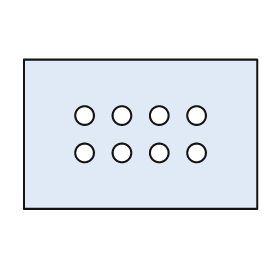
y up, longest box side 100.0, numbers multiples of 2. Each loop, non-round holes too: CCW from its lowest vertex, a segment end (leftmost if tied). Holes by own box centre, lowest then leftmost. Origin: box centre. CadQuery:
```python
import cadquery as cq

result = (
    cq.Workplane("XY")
    .moveTo(-50.0, -32.0)
    .lineTo(50.0, -32.0)
    .lineTo(50.0, 32.0)
    .lineTo(-50.0, 32.0)
    .close()
    .moveTo(-24.0, -8.0)
    .circle(4.0)
    .moveTo(-8.0, -8.0)
    .circle(4.0)
    .moveTo(8.0, -8.0)
    .circle(4.0)
    .moveTo(24.0, -8.0)
    .circle(4.0)
    .moveTo(-24.0, 8.0)
    .circle(4.0)
    .moveTo(-8.0, 8.0)
    .circle(4.0)
    .moveTo(8.0, 8.0)
    .circle(4.0)
    .moveTo(24.0, 8.0)
    .circle(4.0)
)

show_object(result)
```